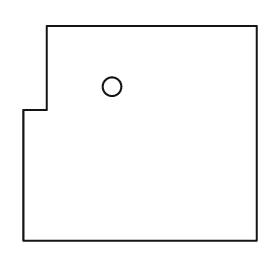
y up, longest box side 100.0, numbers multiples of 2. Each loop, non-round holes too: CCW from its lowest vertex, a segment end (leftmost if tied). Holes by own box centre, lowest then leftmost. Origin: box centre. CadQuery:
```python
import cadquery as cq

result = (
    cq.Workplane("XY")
    .moveTo(-50.0, -46.0)
    .lineTo(50.0, -46.0)
    .lineTo(50.0, 46.0)
    .lineTo(-40.0, 46.0)
    .lineTo(-40.0, 10.0)
    .lineTo(-50.0, 10.0)
    .close()
    .moveTo(-12.0, 20.0)
    .circle(4.0)
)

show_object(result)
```